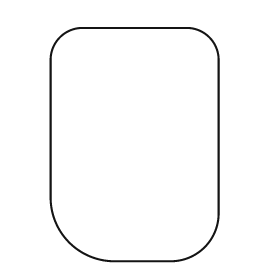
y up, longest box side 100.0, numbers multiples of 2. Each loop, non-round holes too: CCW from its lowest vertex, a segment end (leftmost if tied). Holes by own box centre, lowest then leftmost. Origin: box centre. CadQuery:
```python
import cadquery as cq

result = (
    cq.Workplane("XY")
    .moveTo(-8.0, -50.0)
    .lineTo(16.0, -50.0)
    .threePointArc((30.0, -44.0), (36.0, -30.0))
    .lineTo(36.0, 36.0)
    .threePointArc((32.0, 46.0), (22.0, 50.0))
    .lineTo(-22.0, 50.0)
    .threePointArc((-32.0, 46.0), (-36.0, 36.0))
    .lineTo(-36.0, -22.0)
    .threePointArc((-28.0, -42.0), (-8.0, -50.0))
    .close()
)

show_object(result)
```